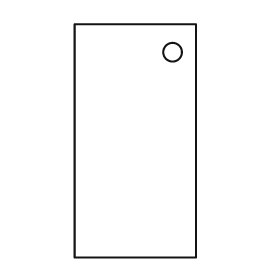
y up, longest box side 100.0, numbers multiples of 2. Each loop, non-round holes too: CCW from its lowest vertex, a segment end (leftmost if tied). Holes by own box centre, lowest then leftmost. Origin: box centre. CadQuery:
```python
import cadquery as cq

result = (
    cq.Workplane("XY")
    .moveTo(-26.0, -50.0)
    .lineTo(26.0, -50.0)
    .lineTo(26.0, 50.0)
    .lineTo(-26.0, 50.0)
    .close()
    .moveTo(16.0, 38.0)
    .circle(4.0)
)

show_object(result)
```